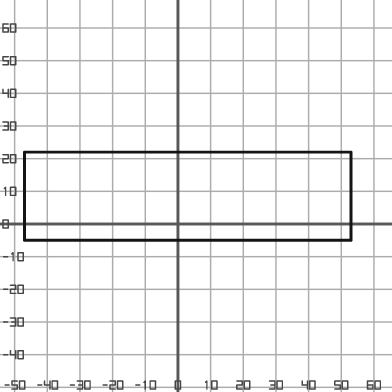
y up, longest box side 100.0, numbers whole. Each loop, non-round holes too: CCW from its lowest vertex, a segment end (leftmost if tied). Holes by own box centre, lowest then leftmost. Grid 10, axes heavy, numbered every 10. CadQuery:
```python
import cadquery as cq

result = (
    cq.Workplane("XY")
    .moveTo(-47.0, -5.0)
    .lineTo(53.0, -5.0)
    .lineTo(53.0, 22.0)
    .lineTo(-47.0, 22.0)
    .close()
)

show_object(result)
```